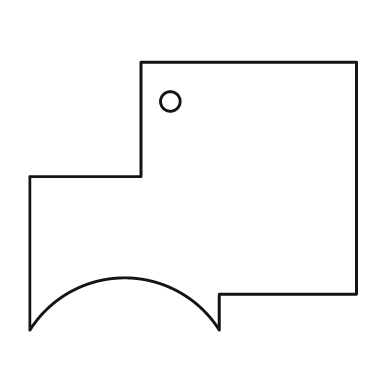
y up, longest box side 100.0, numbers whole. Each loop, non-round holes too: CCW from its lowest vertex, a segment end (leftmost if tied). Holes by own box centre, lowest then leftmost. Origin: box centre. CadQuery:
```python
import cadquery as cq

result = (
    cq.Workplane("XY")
    .moveTo(-50.0, -41.0)
    .threePointArc((-21.0, -25.0), (8.0, -41.0))
    .lineTo(8.0, -30.0)
    .lineTo(50.0, -30.0)
    .lineTo(50.0, 41.0)
    .lineTo(-16.0, 41.0)
    .lineTo(-16.0, 6.0)
    .lineTo(-50.0, 6.0)
    .close()
    .moveTo(-7.0, 29.0)
    .circle(3.0)
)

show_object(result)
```